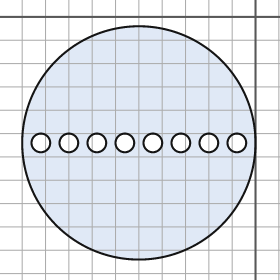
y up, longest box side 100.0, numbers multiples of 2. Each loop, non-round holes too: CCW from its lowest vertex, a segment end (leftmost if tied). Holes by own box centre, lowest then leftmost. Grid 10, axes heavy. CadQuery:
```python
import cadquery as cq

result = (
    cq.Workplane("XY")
    .moveTo(-50.0, -54.0)
    .circle(50.0)
    .moveTo(-92.0, -54.0)
    .circle(4.0)
    .moveTo(-80.0, -54.0)
    .circle(4.0)
    .moveTo(-68.0, -54.0)
    .circle(4.0)
    .moveTo(-56.0, -54.0)
    .circle(4.0)
    .moveTo(-44.0, -54.0)
    .circle(4.0)
    .moveTo(-32.0, -54.0)
    .circle(4.0)
    .moveTo(-20.0, -54.0)
    .circle(4.0)
    .moveTo(-8.0, -54.0)
    .circle(4.0)
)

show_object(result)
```